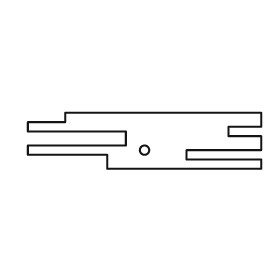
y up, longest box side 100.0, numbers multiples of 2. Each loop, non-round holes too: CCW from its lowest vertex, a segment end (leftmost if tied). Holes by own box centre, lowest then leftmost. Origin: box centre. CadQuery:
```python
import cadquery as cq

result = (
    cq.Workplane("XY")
    .moveTo(-16.0, -12.0)
    .lineTo(50.0, -12.0)
    .lineTo(50.0, -8.0)
    .lineTo(18.0, -8.0)
    .lineTo(18.0, -4.0)
    .lineTo(50.0, -4.0)
    .lineTo(50.0, 2.0)
    .lineTo(36.0, 2.0)
    .lineTo(36.0, 6.0)
    .lineTo(50.0, 6.0)
    .lineTo(50.0, 12.0)
    .lineTo(-34.0, 12.0)
    .lineTo(-34.0, 8.0)
    .lineTo(-50.0, 8.0)
    .lineTo(-50.0, 4.0)
    .lineTo(-8.0, 4.0)
    .lineTo(-8.0, -2.0)
    .lineTo(-50.0, -2.0)
    .lineTo(-50.0, -6.0)
    .lineTo(-16.0, -6.0)
    .close()
    .moveTo(0.0, -4.0)
    .circle(2.0)
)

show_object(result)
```